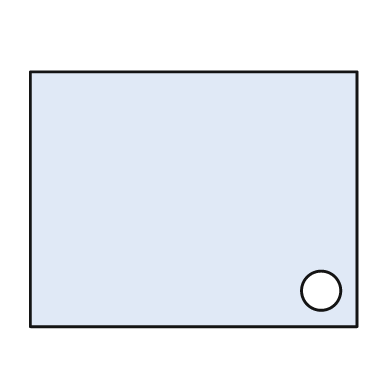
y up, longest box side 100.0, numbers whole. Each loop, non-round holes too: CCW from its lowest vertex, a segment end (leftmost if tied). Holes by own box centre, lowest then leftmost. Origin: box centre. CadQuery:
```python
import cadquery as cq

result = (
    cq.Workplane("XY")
    .moveTo(-50.0, -39.0)
    .lineTo(50.0, -39.0)
    .lineTo(50.0, 39.0)
    .lineTo(-50.0, 39.0)
    .close()
    .moveTo(39.0, -28.0)
    .circle(6.0)
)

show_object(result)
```